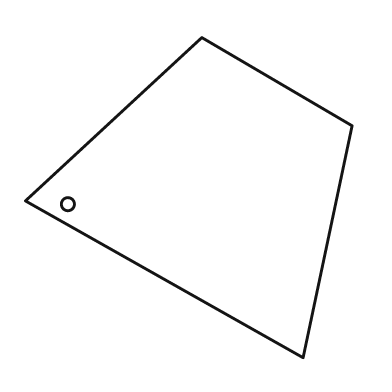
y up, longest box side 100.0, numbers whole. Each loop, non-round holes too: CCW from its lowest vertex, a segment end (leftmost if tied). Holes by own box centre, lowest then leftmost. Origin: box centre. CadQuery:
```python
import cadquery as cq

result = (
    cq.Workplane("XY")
    .moveTo(35.0, -49.0)
    .lineTo(50.0, 22.0)
    .lineTo(4.0, 49.0)
    .lineTo(-50.0, -1.0)
    .close()
    .moveTo(-37.0, -2.0)
    .circle(2.0)
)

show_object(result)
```